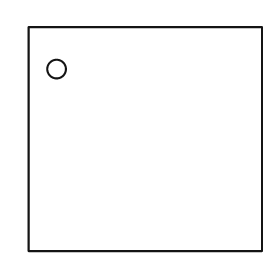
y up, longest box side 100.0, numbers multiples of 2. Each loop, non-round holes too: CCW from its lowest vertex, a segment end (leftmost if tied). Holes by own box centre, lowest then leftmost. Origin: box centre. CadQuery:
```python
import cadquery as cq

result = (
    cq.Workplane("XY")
    .moveTo(-50.0, -48.0)
    .lineTo(50.0, -48.0)
    .lineTo(50.0, 48.0)
    .lineTo(-50.0, 48.0)
    .close()
    .moveTo(-38.0, 30.0)
    .circle(4.0)
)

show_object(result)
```